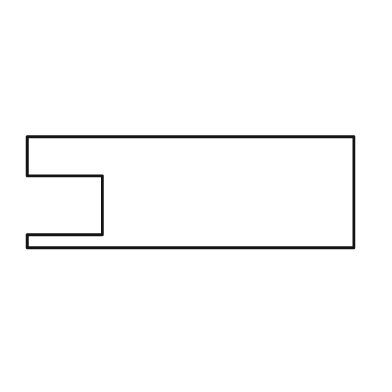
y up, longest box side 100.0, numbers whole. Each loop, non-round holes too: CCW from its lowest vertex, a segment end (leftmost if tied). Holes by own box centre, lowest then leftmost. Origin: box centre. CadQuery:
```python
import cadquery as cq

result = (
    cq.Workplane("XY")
    .moveTo(-50.0, -17.0)
    .lineTo(50.0, -17.0)
    .lineTo(50.0, 17.0)
    .lineTo(-50.0, 17.0)
    .lineTo(-50.0, 5.0)
    .lineTo(-27.0, 5.0)
    .lineTo(-27.0, -13.0)
    .lineTo(-50.0, -13.0)
    .close()
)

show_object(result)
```